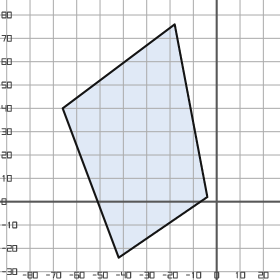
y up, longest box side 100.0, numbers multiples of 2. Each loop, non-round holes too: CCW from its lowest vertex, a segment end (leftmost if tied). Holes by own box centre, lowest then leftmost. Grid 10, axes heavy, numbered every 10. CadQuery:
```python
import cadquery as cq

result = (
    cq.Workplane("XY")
    .moveTo(-42.0, -24.0)
    .lineTo(-4.0, 2.0)
    .lineTo(-18.0, 76.0)
    .lineTo(-66.0, 40.0)
    .close()
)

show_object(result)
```